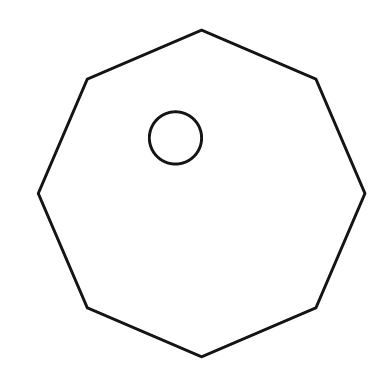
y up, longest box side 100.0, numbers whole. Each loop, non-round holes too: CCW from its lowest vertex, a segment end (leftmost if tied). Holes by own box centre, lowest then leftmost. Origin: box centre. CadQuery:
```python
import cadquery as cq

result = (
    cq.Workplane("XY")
    .moveTo(0.0, -50.0)
    .lineTo(35.0, -35.0)
    .lineTo(50.0, 0.0)
    .lineTo(35.0, 35.0)
    .lineTo(0.0, 50.0)
    .lineTo(-35.0, 35.0)
    .lineTo(-50.0, 0.0)
    .lineTo(-35.0, -35.0)
    .close()
    .moveTo(-8.0, 17.0)
    .circle(8.0)
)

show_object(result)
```